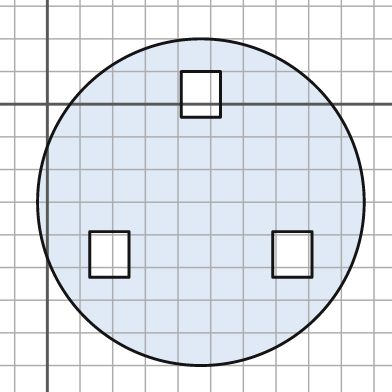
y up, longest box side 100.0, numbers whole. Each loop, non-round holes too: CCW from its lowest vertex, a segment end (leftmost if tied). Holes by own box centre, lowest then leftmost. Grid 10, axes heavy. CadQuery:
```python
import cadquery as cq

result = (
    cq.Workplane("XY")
    .moveTo(47.0, -30.0)
    .circle(50.0)
    .moveTo(13.0, -53.0)
    .lineTo(25.0, -53.0)
    .lineTo(25.0, -39.0)
    .lineTo(13.0, -39.0)
    .close()
    .moveTo(69.0, -53.0)
    .lineTo(81.0, -53.0)
    .lineTo(81.0, -39.0)
    .lineTo(69.0, -39.0)
    .close()
    .moveTo(41.0, -4.0)
    .lineTo(53.0, -4.0)
    .lineTo(53.0, 10.0)
    .lineTo(41.0, 10.0)
    .close()
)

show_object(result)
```